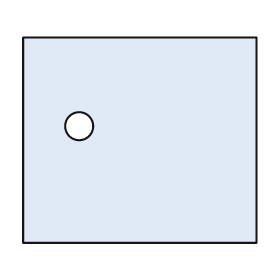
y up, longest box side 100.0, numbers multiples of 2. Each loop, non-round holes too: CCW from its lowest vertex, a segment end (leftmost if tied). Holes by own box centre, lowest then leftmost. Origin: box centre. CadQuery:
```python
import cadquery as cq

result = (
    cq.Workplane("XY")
    .moveTo(-50.0, -44.0)
    .lineTo(50.0, -44.0)
    .lineTo(50.0, 44.0)
    .lineTo(-50.0, 44.0)
    .close()
    .moveTo(-26.0, 6.0)
    .circle(6.0)
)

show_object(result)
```